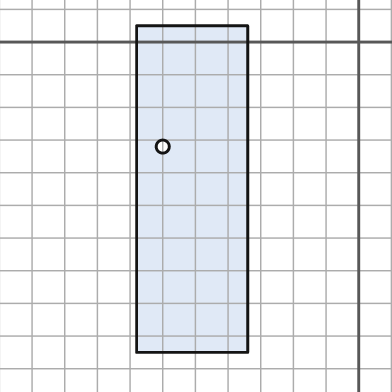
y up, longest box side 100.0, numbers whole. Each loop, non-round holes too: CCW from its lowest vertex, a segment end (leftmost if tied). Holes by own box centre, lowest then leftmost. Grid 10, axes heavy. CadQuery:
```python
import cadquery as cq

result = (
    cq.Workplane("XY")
    .moveTo(-68.0, -95.0)
    .lineTo(-34.0, -95.0)
    .lineTo(-34.0, 5.0)
    .lineTo(-68.0, 5.0)
    .close()
    .moveTo(-60.0, -32.0)
    .circle(2.0)
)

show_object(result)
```